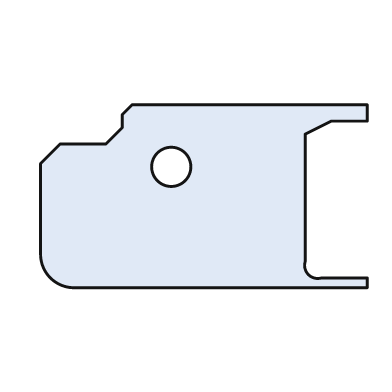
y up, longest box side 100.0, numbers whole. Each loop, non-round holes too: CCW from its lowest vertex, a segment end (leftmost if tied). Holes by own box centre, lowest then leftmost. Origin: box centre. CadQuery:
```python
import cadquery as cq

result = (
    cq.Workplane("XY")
    .moveTo(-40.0, -28.0)
    .lineTo(50.0, -28.0)
    .lineTo(50.0, -25.0)
    .lineTo(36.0, -25.0)
    .threePointArc((32.0, -24.0), (31.0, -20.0))
    .lineTo(31.0, 19.0)
    .lineTo(39.0, 23.0)
    .lineTo(50.0, 23.0)
    .lineTo(50.0, 28.0)
    .lineTo(-22.0, 28.0)
    .lineTo(-25.0, 25.0)
    .lineTo(-25.0, 21.0)
    .lineTo(-30.0, 16.0)
    .lineTo(-44.0, 16.0)
    .lineTo(-50.0, 10.0)
    .lineTo(-50.0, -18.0)
    .threePointArc((-47.0, -25.0), (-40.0, -28.0))
    .close()
    .moveTo(-10.0, 9.0)
    .circle(6.0)
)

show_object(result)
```